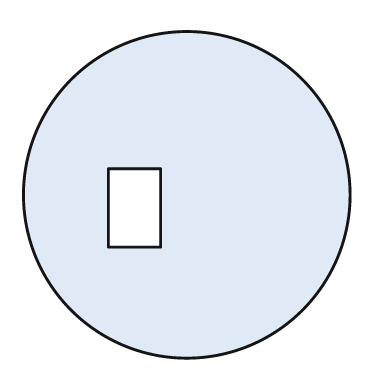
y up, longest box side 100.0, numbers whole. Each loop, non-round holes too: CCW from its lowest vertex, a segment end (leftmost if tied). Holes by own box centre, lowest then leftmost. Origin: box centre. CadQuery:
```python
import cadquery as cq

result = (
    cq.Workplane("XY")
    .moveTo(0.0, 0.0)
    .circle(50.0)
    .moveTo(-24.0, -16.0)
    .lineTo(-8.0, -16.0)
    .lineTo(-8.0, 8.0)
    .lineTo(-24.0, 8.0)
    .close()
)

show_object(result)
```